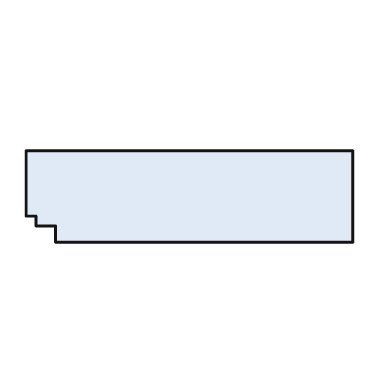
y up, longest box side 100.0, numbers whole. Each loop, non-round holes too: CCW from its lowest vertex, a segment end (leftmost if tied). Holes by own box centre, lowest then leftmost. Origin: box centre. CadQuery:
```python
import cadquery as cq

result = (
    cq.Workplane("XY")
    .moveTo(-41.0, -14.0)
    .lineTo(50.0, -14.0)
    .lineTo(50.0, 14.0)
    .lineTo(-50.0, 14.0)
    .lineTo(-50.0, -6.0)
    .lineTo(-47.0, -6.0)
    .lineTo(-47.0, -9.0)
    .lineTo(-41.0, -9.0)
    .close()
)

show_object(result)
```